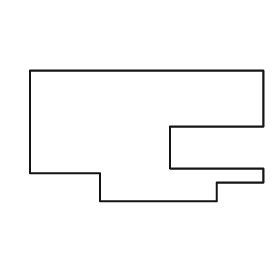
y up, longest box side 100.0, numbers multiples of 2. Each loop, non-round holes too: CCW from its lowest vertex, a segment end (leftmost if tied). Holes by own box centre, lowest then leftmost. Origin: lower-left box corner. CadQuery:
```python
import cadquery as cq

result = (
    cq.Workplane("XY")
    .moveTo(30.0, 0.0)
    .lineTo(80.0, 0.0)
    .lineTo(80.0, 8.0)
    .lineTo(100.0, 8.0)
    .lineTo(100.0, 14.0)
    .lineTo(60.0, 14.0)
    .lineTo(60.0, 32.0)
    .lineTo(100.0, 32.0)
    .lineTo(100.0, 56.0)
    .lineTo(0.0, 56.0)
    .lineTo(0.0, 12.0)
    .lineTo(30.0, 12.0)
    .close()
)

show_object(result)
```